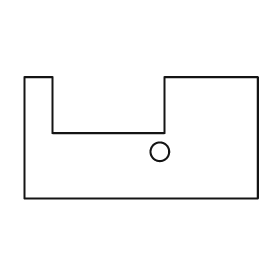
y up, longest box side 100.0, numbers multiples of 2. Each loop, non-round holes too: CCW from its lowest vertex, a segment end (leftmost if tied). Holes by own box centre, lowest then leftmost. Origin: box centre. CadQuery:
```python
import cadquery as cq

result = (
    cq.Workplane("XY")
    .moveTo(-50.0, -26.0)
    .lineTo(50.0, -26.0)
    .lineTo(50.0, 26.0)
    .lineTo(10.0, 26.0)
    .lineTo(10.0, 2.0)
    .lineTo(-38.0, 2.0)
    .lineTo(-38.0, 26.0)
    .lineTo(-50.0, 26.0)
    .close()
    .moveTo(8.0, -6.0)
    .circle(4.0)
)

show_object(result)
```